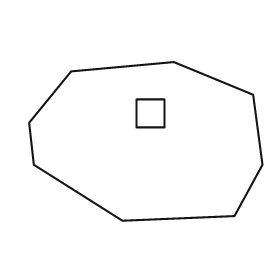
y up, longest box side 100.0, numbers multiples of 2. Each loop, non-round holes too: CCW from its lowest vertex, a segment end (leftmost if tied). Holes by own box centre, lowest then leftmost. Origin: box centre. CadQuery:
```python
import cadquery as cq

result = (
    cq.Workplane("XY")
    .moveTo(-10.0, -34.0)
    .lineTo(38.0, -32.0)
    .lineTo(50.0, -10.0)
    .lineTo(46.0, 20.0)
    .lineTo(12.0, 34.0)
    .lineTo(-32.0, 30.0)
    .lineTo(-50.0, 8.0)
    .lineTo(-48.0, -10.0)
    .close()
    .moveTo(-4.0, 6.0)
    .lineTo(8.0, 6.0)
    .lineTo(8.0, 18.0)
    .lineTo(-4.0, 18.0)
    .close()
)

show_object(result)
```